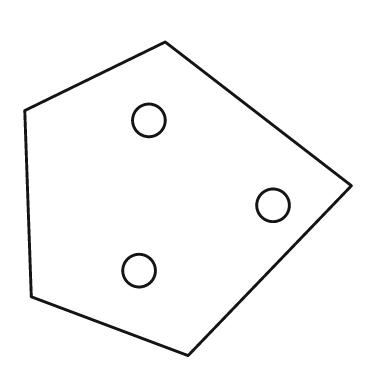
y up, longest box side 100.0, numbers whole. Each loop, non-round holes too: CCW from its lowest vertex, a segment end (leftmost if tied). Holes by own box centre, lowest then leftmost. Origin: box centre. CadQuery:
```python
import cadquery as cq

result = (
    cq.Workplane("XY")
    .moveTo(0.0, -48.0)
    .lineTo(50.0, 4.0)
    .lineTo(-7.0, 48.0)
    .lineTo(-50.0, 27.0)
    .lineTo(-48.0, -30.0)
    .close()
    .moveTo(-15.0, -22.0)
    .circle(5.0)
    .moveTo(26.0, -2.0)
    .circle(5.0)
    .moveTo(-12.0, 24.0)
    .circle(5.0)
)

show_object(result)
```